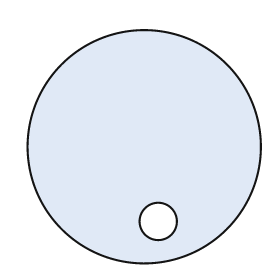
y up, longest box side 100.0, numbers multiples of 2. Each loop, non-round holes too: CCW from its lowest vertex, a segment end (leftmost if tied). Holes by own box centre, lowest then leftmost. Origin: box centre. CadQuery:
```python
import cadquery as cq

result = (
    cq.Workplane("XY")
    .moveTo(0.0, 0.0)
    .circle(50.0)
    .moveTo(6.0, -32.0)
    .circle(8.0)
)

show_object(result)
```